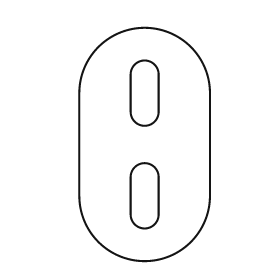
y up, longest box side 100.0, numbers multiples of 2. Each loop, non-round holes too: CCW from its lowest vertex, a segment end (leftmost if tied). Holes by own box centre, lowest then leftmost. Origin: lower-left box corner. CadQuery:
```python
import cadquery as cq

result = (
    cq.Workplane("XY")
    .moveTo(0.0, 28.0)
    .threePointArc((28.0, 0.0), (56.0, 28.0))
    .lineTo(56.0, 72.0)
    .threePointArc((28.0, 100.0), (0.0, 72.0))
    .close()
    .moveTo(22.0, 20.0)
    .threePointArc((28.0, 14.0), (34.0, 20.0))
    .lineTo(34.0, 36.0)
    .threePointArc((28.0, 42.0), (22.0, 36.0))
    .close()
    .moveTo(22.0, 64.0)
    .threePointArc((28.0, 58.0), (34.0, 64.0))
    .lineTo(34.0, 80.0)
    .threePointArc((28.0, 86.0), (22.0, 80.0))
    .close()
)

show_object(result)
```